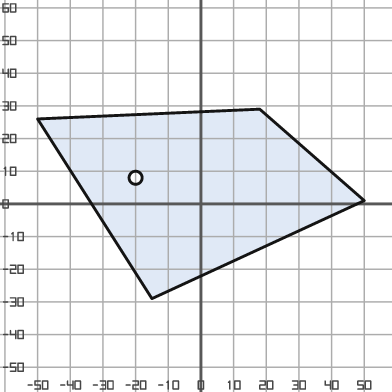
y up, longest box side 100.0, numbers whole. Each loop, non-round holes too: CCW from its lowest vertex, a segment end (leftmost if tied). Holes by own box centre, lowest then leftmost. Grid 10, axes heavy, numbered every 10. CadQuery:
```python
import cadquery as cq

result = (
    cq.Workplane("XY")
    .moveTo(-15.0, -29.0)
    .lineTo(50.0, 1.0)
    .lineTo(18.0, 29.0)
    .lineTo(-50.0, 26.0)
    .close()
    .moveTo(-20.0, 8.0)
    .circle(2.0)
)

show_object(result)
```